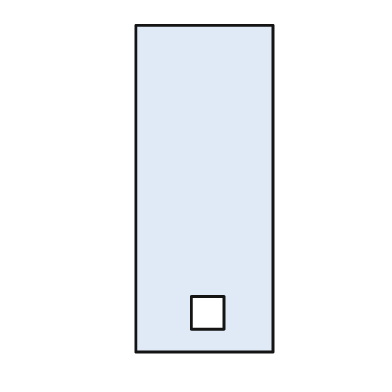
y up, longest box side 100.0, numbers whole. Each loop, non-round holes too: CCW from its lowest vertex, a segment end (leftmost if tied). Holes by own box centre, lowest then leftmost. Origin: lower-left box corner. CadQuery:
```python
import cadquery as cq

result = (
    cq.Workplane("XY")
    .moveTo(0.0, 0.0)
    .lineTo(42.0, 0.0)
    .lineTo(42.0, 100.0)
    .lineTo(0.0, 100.0)
    .close()
    .moveTo(17.0, 7.0)
    .lineTo(27.0, 7.0)
    .lineTo(27.0, 17.0)
    .lineTo(17.0, 17.0)
    .close()
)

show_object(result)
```